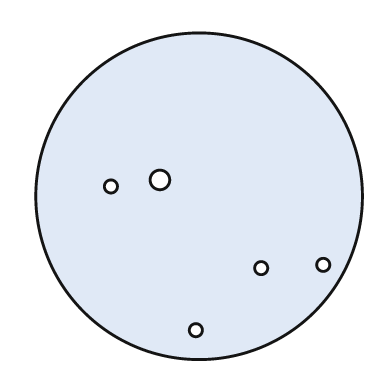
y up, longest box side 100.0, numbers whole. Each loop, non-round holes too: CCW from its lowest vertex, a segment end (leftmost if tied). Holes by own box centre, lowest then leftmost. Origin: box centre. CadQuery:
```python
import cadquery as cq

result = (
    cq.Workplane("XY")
    .moveTo(0.0, 0.0)
    .circle(50.0)
    .moveTo(-1.0, -41.0)
    .circle(2.0)
    .moveTo(19.0, -22.0)
    .circle(2.0)
    .moveTo(38.0, -21.0)
    .circle(2.0)
    .moveTo(-27.0, 3.0)
    .circle(2.0)
    .moveTo(-12.0, 5.0)
    .circle(3.0)
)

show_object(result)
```